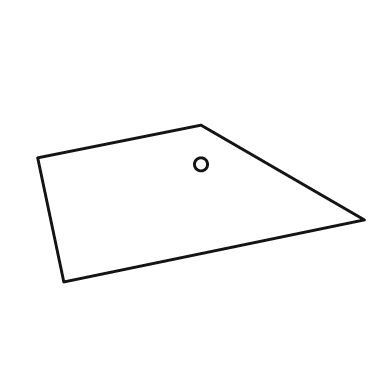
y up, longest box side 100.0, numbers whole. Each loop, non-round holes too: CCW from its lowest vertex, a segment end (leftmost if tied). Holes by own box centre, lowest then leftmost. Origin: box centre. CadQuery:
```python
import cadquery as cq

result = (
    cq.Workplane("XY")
    .moveTo(-42.0, -24.0)
    .lineTo(50.0, -5.0)
    .lineTo(0.0, 24.0)
    .lineTo(-50.0, 14.0)
    .close()
    .moveTo(0.0, 12.0)
    .circle(2.0)
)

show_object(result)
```